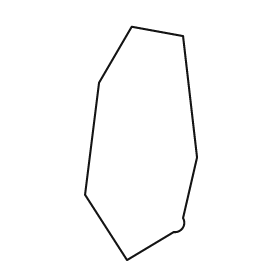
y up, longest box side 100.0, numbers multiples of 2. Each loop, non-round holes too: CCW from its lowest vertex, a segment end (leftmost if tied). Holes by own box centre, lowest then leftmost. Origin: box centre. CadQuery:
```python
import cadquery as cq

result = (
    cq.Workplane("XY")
    .moveTo(-6.0, -50.0)
    .lineTo(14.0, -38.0)
    .threePointArc((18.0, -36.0), (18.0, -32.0))
    .lineTo(24.0, -6.0)
    .lineTo(18.0, 46.0)
    .lineTo(-4.0, 50.0)
    .lineTo(-18.0, 26.0)
    .lineTo(-24.0, -22.0)
    .close()
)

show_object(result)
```